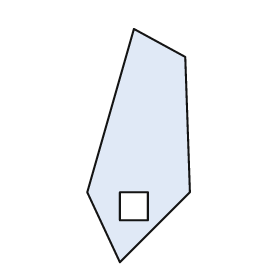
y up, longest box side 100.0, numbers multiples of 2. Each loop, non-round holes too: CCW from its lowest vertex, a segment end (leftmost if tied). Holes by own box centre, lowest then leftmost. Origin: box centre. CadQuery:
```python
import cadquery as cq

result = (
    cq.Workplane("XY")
    .moveTo(-8.0, -50.0)
    .lineTo(22.0, -20.0)
    .lineTo(20.0, 38.0)
    .lineTo(-2.0, 50.0)
    .lineTo(-22.0, -20.0)
    .close()
    .moveTo(-8.0, -32.0)
    .lineTo(4.0, -32.0)
    .lineTo(4.0, -20.0)
    .lineTo(-8.0, -20.0)
    .close()
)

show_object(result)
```